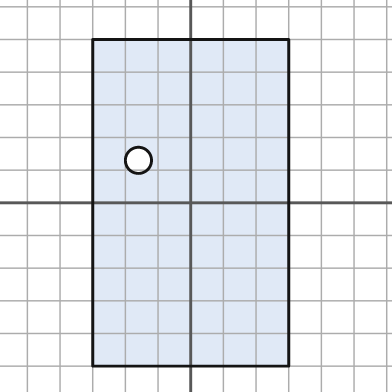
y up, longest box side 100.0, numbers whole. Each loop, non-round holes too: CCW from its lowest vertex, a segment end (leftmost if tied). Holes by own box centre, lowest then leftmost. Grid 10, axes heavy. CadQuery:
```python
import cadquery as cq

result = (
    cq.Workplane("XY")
    .moveTo(-30.0, -50.0)
    .lineTo(30.0, -50.0)
    .lineTo(30.0, 50.0)
    .lineTo(-30.0, 50.0)
    .close()
    .moveTo(-16.0, 13.0)
    .circle(4.0)
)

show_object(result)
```